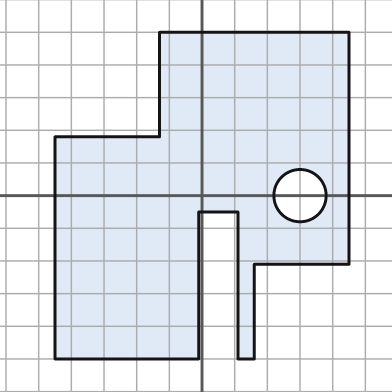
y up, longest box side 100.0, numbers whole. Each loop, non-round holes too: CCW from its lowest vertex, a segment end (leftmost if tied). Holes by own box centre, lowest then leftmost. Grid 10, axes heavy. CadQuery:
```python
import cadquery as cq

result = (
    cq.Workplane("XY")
    .moveTo(-45.0, -50.0)
    .lineTo(-1.0, -50.0)
    .lineTo(-1.0, -5.0)
    .lineTo(11.0, -5.0)
    .lineTo(11.0, -50.0)
    .lineTo(16.0, -50.0)
    .lineTo(16.0, -21.0)
    .lineTo(45.0, -21.0)
    .lineTo(45.0, 50.0)
    .lineTo(-13.0, 50.0)
    .lineTo(-13.0, 18.0)
    .lineTo(-45.0, 18.0)
    .close()
    .moveTo(30.0, 0.0)
    .circle(8.0)
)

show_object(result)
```